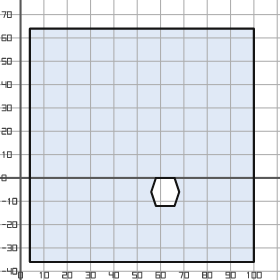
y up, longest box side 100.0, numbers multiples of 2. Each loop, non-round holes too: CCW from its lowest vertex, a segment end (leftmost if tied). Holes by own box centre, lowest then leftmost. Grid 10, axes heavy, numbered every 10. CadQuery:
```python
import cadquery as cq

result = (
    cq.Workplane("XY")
    .moveTo(4.0, -36.0)
    .lineTo(100.0, -36.0)
    .lineTo(100.0, 64.0)
    .lineTo(4.0, 64.0)
    .close()
    .moveTo(58.0, -12.0)
    .lineTo(66.0, -12.0)
    .lineTo(68.0, -6.0)
    .lineTo(66.0, 0.0)
    .lineTo(58.0, 0.0)
    .lineTo(56.0, -6.0)
    .close()
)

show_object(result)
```